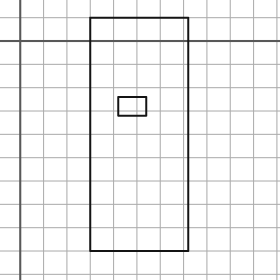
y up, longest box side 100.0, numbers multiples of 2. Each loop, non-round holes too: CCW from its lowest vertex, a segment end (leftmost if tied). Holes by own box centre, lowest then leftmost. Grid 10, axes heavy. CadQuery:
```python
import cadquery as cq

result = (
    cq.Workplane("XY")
    .moveTo(30.0, -90.0)
    .lineTo(72.0, -90.0)
    .lineTo(72.0, 10.0)
    .lineTo(30.0, 10.0)
    .close()
    .moveTo(42.0, -32.0)
    .lineTo(54.0, -32.0)
    .lineTo(54.0, -24.0)
    .lineTo(42.0, -24.0)
    .close()
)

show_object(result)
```